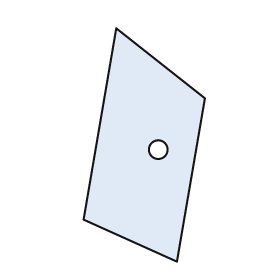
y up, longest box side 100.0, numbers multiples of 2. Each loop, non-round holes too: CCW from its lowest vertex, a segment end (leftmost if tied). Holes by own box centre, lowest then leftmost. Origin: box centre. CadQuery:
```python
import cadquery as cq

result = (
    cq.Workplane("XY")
    .moveTo(14.0, -50.0)
    .lineTo(26.0, 20.0)
    .lineTo(-12.0, 50.0)
    .lineTo(-26.0, -32.0)
    .close()
    .moveTo(6.0, -2.0)
    .circle(4.0)
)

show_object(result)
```